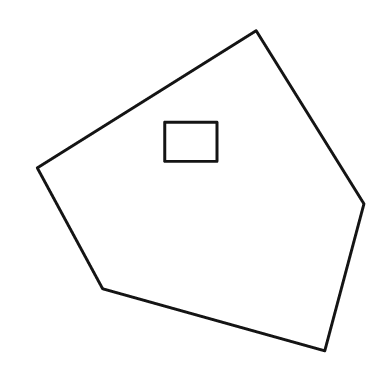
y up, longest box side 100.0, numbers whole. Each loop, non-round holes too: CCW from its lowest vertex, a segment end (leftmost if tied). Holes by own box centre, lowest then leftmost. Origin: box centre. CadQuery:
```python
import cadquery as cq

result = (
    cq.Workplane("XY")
    .moveTo(38.0, -49.0)
    .lineTo(50.0, -4.0)
    .lineTo(17.0, 49.0)
    .lineTo(-50.0, 7.0)
    .lineTo(-30.0, -30.0)
    .close()
    .moveTo(-11.0, 9.0)
    .lineTo(5.0, 9.0)
    .lineTo(5.0, 21.0)
    .lineTo(-11.0, 21.0)
    .close()
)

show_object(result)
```